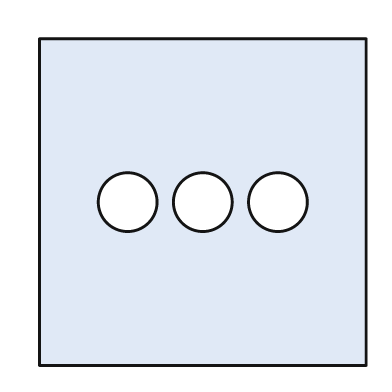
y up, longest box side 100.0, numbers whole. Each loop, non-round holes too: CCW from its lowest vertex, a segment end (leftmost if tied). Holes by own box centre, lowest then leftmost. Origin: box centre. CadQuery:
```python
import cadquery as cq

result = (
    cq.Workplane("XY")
    .moveTo(-50.0, -50.0)
    .lineTo(50.0, -50.0)
    .lineTo(50.0, 50.0)
    .lineTo(-50.0, 50.0)
    .close()
    .moveTo(-23.0, 0.0)
    .circle(9.0)
    .moveTo(0.0, 0.0)
    .circle(9.0)
    .moveTo(23.0, 0.0)
    .circle(9.0)
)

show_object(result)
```